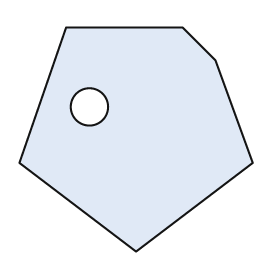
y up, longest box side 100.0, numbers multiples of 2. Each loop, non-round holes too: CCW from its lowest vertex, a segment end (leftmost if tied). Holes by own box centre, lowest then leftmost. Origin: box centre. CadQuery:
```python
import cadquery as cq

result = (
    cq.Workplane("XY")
    .moveTo(0.0, -48.0)
    .lineTo(50.0, -10.0)
    .lineTo(34.0, 34.0)
    .lineTo(20.0, 48.0)
    .lineTo(-30.0, 48.0)
    .lineTo(-50.0, -10.0)
    .close()
    .moveTo(-20.0, 14.0)
    .circle(8.0)
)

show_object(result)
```